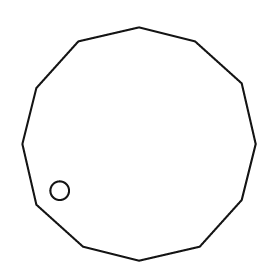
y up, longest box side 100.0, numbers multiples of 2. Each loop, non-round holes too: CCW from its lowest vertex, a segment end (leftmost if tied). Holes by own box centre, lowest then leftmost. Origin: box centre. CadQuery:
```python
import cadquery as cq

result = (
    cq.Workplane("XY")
    .moveTo(0.0, -50.0)
    .lineTo(26.0, -44.0)
    .lineTo(44.0, -24.0)
    .lineTo(50.0, 0.0)
    .lineTo(44.0, 26.0)
    .lineTo(24.0, 44.0)
    .lineTo(0.0, 50.0)
    .lineTo(-26.0, 44.0)
    .lineTo(-44.0, 24.0)
    .lineTo(-50.0, 0.0)
    .lineTo(-44.0, -26.0)
    .lineTo(-24.0, -44.0)
    .close()
    .moveTo(-34.0, -20.0)
    .circle(4.0)
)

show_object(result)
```